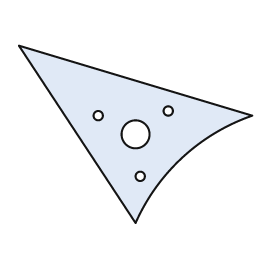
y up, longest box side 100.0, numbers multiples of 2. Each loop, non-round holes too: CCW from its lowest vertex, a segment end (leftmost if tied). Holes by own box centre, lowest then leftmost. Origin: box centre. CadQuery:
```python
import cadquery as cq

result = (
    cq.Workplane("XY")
    .moveTo(0.0, -38.0)
    .threePointArc((20.0, -10.0), (50.0, 8.0))
    .lineTo(-50.0, 38.0)
    .close()
    .moveTo(2.0, -18.0)
    .circle(2.0)
    .moveTo(0.0, 0.0)
    .circle(6.0)
    .moveTo(-16.0, 8.0)
    .circle(2.0)
    .moveTo(14.0, 10.0)
    .circle(2.0)
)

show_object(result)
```